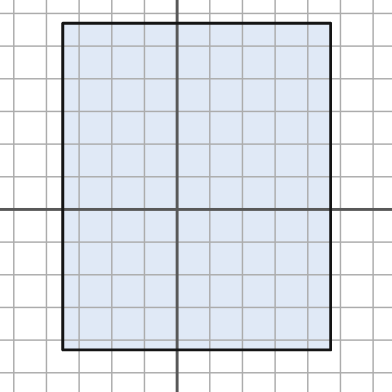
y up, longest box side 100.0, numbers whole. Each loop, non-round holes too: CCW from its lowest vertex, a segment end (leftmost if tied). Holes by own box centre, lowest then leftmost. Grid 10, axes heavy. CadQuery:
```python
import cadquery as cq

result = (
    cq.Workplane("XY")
    .moveTo(-35.0, -43.0)
    .lineTo(47.0, -43.0)
    .lineTo(47.0, 57.0)
    .lineTo(-35.0, 57.0)
    .close()
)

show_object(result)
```